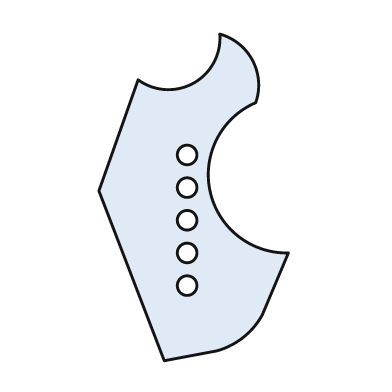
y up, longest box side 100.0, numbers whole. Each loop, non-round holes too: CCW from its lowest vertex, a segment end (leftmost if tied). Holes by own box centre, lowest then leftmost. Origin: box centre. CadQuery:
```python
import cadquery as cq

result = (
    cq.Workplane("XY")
    .moveTo(-9.0, -50.0)
    .lineTo(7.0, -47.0)
    .threePointArc((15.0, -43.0), (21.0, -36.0))
    .lineTo(29.0, -17.0)
    .threePointArc((5.0, 2.0), (19.0, 29.0))
    .threePointArc((18.0, 42.0), (8.0, 50.0))
    .threePointArc((0.0, 35.0), (-17.0, 36.0))
    .lineTo(-29.0, 2.0)
    .close()
    .moveTo(-2.0, -27.0)
    .circle(3.0)
    .moveTo(-2.0, -17.0)
    .circle(3.0)
    .moveTo(-2.0, -7.0)
    .circle(3.0)
    .moveTo(-2.0, 3.0)
    .circle(3.0)
    .moveTo(-2.0, 13.0)
    .circle(3.0)
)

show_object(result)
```